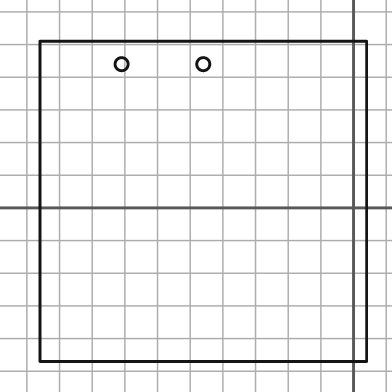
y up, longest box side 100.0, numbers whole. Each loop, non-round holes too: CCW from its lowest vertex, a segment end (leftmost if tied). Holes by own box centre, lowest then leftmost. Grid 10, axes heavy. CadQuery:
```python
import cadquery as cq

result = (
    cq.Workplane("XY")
    .moveTo(-96.0, -47.0)
    .lineTo(4.0, -47.0)
    .lineTo(4.0, 51.0)
    .lineTo(-96.0, 51.0)
    .close()
    .moveTo(-71.0, 44.0)
    .circle(2.0)
    .moveTo(-46.0, 44.0)
    .circle(2.0)
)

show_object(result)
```